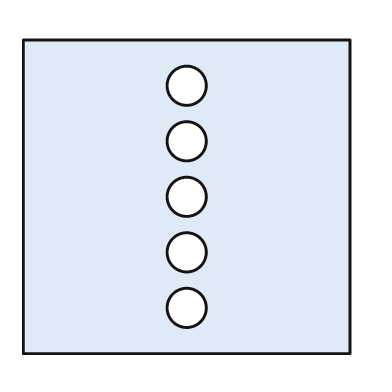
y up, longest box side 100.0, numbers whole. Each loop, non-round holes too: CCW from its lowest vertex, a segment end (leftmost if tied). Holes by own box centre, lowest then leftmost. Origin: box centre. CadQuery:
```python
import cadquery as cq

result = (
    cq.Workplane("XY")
    .moveTo(-50.0, -48.0)
    .lineTo(50.0, -48.0)
    .lineTo(50.0, 48.0)
    .lineTo(-50.0, 48.0)
    .close()
    .moveTo(0.0, -34.0)
    .circle(6.0)
    .moveTo(0.0, -17.0)
    .circle(6.0)
    .moveTo(0.0, 0.0)
    .circle(6.0)
    .moveTo(0.0, 17.0)
    .circle(6.0)
    .moveTo(0.0, 34.0)
    .circle(6.0)
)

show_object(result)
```